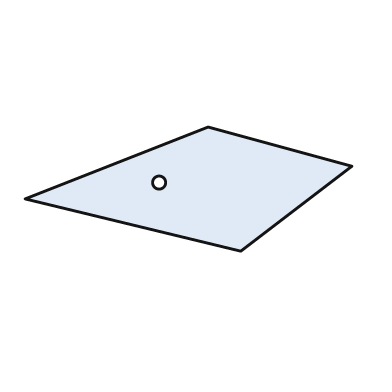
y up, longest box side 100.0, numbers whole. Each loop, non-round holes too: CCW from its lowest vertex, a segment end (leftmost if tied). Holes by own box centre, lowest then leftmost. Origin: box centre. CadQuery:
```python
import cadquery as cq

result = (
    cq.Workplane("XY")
    .moveTo(16.0, -19.0)
    .lineTo(50.0, 7.0)
    .lineTo(6.0, 19.0)
    .lineTo(-50.0, -3.0)
    .close()
    .moveTo(-9.0, 2.0)
    .circle(2.0)
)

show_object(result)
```